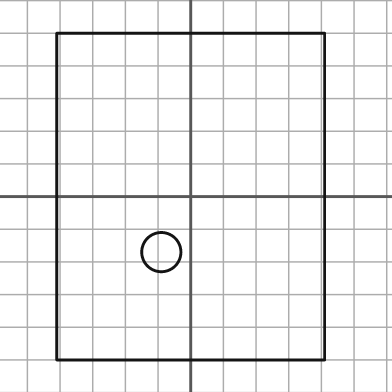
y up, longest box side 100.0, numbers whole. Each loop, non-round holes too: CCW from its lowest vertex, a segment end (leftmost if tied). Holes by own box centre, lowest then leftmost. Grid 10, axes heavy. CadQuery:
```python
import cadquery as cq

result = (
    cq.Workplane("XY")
    .moveTo(-41.0, -50.0)
    .lineTo(41.0, -50.0)
    .lineTo(41.0, 50.0)
    .lineTo(-41.0, 50.0)
    .close()
    .moveTo(-9.0, -17.0)
    .circle(6.0)
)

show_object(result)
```